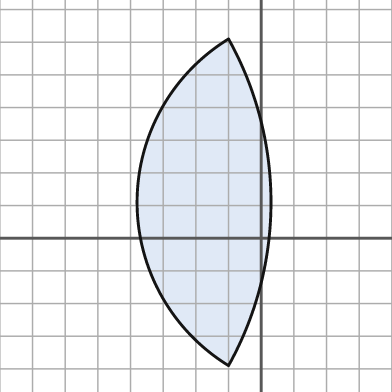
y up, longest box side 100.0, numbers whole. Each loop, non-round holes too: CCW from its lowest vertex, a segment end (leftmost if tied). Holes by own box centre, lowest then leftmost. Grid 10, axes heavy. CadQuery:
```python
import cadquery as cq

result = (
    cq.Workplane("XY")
    .moveTo(-10.0, -39.0)
    .threePointArc((3.0, 11.0), (-10.0, 61.0))
    .threePointArc((-38.0, 11.0), (-10.0, -39.0))
    .close()
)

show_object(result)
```